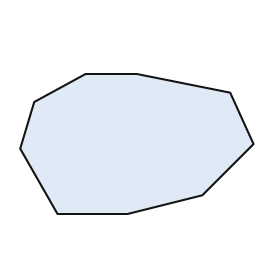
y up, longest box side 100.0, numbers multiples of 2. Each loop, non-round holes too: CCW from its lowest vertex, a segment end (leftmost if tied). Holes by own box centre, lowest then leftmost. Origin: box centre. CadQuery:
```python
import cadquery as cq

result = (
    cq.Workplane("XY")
    .moveTo(-34.0, -30.0)
    .lineTo(-4.0, -30.0)
    .lineTo(28.0, -22.0)
    .lineTo(50.0, 0.0)
    .lineTo(40.0, 22.0)
    .lineTo(0.0, 30.0)
    .lineTo(-22.0, 30.0)
    .lineTo(-44.0, 18.0)
    .lineTo(-50.0, -2.0)
    .close()
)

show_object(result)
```